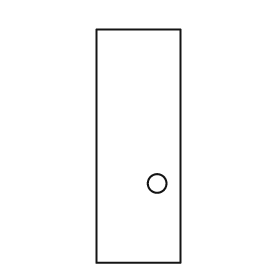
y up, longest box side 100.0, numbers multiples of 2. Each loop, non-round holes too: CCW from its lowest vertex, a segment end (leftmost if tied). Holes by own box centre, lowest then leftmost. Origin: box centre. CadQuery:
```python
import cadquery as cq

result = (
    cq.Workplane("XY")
    .moveTo(-18.0, -50.0)
    .lineTo(18.0, -50.0)
    .lineTo(18.0, 50.0)
    .lineTo(-18.0, 50.0)
    .close()
    .moveTo(8.0, -16.0)
    .circle(4.0)
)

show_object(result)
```